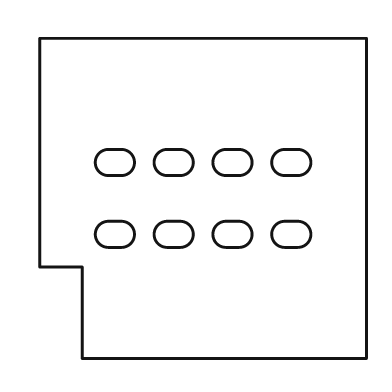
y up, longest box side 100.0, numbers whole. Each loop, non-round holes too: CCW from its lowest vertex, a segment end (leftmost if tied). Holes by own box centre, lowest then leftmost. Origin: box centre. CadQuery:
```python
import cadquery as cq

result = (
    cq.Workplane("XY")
    .moveTo(-37.0, -49.0)
    .lineTo(50.0, -49.0)
    .lineTo(50.0, 49.0)
    .lineTo(-50.0, 49.0)
    .lineTo(-50.0, -21.0)
    .lineTo(-37.0, -21.0)
    .close()
    .moveTo(-29.0, -15.0)
    .lineTo(-25.0, -15.0)
    .threePointArc((-21.0, -11.0), (-25.0, -7.0))
    .lineTo(-29.0, -7.0)
    .threePointArc((-33.0, -11.0), (-29.0, -15.0))
    .close()
    .moveTo(-11.0, -15.0)
    .lineTo(-7.0, -15.0)
    .threePointArc((-3.0, -11.0), (-7.0, -7.0))
    .lineTo(-11.0, -7.0)
    .threePointArc((-15.0, -11.0), (-11.0, -15.0))
    .close()
    .moveTo(7.0, -15.0)
    .lineTo(11.0, -15.0)
    .threePointArc((15.0, -11.0), (11.0, -7.0))
    .lineTo(7.0, -7.0)
    .threePointArc((3.0, -11.0), (7.0, -15.0))
    .close()
    .moveTo(25.0, -15.0)
    .lineTo(29.0, -15.0)
    .threePointArc((33.0, -11.0), (29.0, -7.0))
    .lineTo(25.0, -7.0)
    .threePointArc((21.0, -11.0), (25.0, -15.0))
    .close()
    .moveTo(-29.0, 7.0)
    .lineTo(-25.0, 7.0)
    .threePointArc((-21.0, 11.0), (-25.0, 15.0))
    .lineTo(-29.0, 15.0)
    .threePointArc((-33.0, 11.0), (-29.0, 7.0))
    .close()
    .moveTo(-11.0, 7.0)
    .lineTo(-7.0, 7.0)
    .threePointArc((-3.0, 11.0), (-7.0, 15.0))
    .lineTo(-11.0, 15.0)
    .threePointArc((-15.0, 11.0), (-11.0, 7.0))
    .close()
    .moveTo(7.0, 7.0)
    .lineTo(11.0, 7.0)
    .threePointArc((15.0, 11.0), (11.0, 15.0))
    .lineTo(7.0, 15.0)
    .threePointArc((3.0, 11.0), (7.0, 7.0))
    .close()
    .moveTo(25.0, 7.0)
    .lineTo(29.0, 7.0)
    .threePointArc((33.0, 11.0), (29.0, 15.0))
    .lineTo(25.0, 15.0)
    .threePointArc((21.0, 11.0), (25.0, 7.0))
    .close()
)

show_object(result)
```